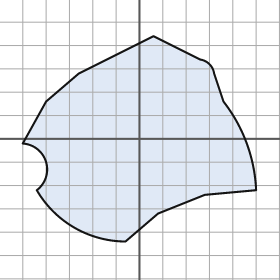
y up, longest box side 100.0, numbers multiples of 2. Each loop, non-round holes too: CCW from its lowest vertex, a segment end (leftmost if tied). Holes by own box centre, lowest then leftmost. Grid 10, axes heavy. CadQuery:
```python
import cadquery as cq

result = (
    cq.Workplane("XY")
    .moveTo(-6.0, -44.0)
    .lineTo(8.0, -32.0)
    .lineTo(28.0, -24.0)
    .lineTo(50.0, -22.0)
    .threePointArc((46.0, -2.0), (36.0, 16.0))
    .lineTo(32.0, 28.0)
    .threePointArc((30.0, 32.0), (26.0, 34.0))
    .lineTo(6.0, 44.0)
    .lineTo(-26.0, 28.0)
    .lineTo(-40.0, 16.0)
    .lineTo(-50.0, -2.0)
    .threePointArc((-40.0, -10.0), (-44.0, -22.0))
    .threePointArc((-28.0, -38.0), (-6.0, -44.0))
    .close()
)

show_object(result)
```